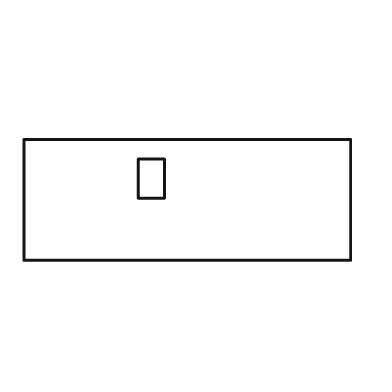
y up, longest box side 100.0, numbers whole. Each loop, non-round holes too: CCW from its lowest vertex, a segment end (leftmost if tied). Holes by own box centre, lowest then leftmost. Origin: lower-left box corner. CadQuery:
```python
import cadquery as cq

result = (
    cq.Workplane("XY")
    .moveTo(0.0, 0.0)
    .lineTo(100.0, 0.0)
    .lineTo(100.0, 37.0)
    .lineTo(0.0, 37.0)
    .close()
    .moveTo(35.0, 19.0)
    .lineTo(43.0, 19.0)
    .lineTo(43.0, 31.0)
    .lineTo(35.0, 31.0)
    .close()
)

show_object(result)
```